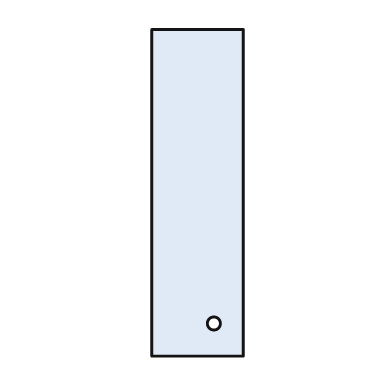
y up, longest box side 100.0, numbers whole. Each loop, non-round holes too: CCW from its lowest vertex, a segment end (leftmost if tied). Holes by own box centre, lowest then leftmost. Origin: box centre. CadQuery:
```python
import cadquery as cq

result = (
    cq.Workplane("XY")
    .moveTo(-14.0, -50.0)
    .lineTo(14.0, -50.0)
    .lineTo(14.0, 50.0)
    .lineTo(-14.0, 50.0)
    .close()
    .moveTo(5.0, -40.0)
    .circle(2.0)
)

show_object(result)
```